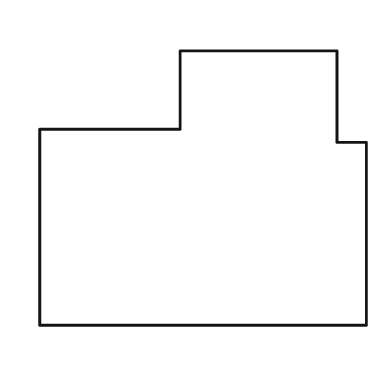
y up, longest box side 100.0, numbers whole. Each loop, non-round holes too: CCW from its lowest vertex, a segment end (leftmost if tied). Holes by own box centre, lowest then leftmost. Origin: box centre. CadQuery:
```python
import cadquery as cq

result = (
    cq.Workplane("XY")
    .moveTo(-50.0, -42.0)
    .lineTo(50.0, -42.0)
    .lineTo(50.0, 14.0)
    .lineTo(41.0, 14.0)
    .lineTo(41.0, 42.0)
    .lineTo(-7.0, 42.0)
    .lineTo(-7.0, 18.0)
    .lineTo(-50.0, 18.0)
    .close()
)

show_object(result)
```